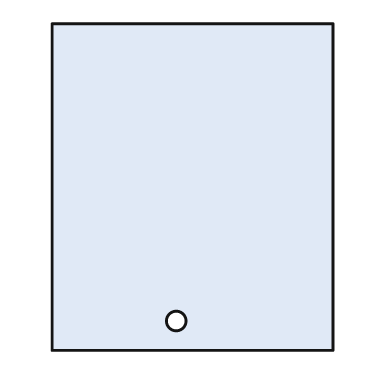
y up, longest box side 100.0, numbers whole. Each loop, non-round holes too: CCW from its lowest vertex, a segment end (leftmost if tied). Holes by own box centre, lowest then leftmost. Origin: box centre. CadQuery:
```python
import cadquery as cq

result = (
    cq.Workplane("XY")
    .moveTo(-43.0, -50.0)
    .lineTo(43.0, -50.0)
    .lineTo(43.0, 50.0)
    .lineTo(-43.0, 50.0)
    .close()
    .moveTo(-5.0, -41.0)
    .circle(3.0)
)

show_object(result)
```